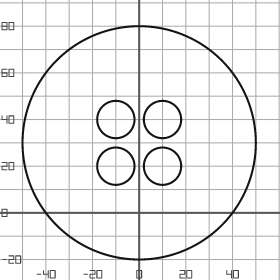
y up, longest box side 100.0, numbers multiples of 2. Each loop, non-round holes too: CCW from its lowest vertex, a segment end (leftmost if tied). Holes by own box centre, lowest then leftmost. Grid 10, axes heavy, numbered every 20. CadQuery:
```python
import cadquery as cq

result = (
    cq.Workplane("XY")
    .moveTo(0.0, 30.0)
    .circle(50.0)
    .moveTo(-10.0, 20.0)
    .circle(8.0)
    .moveTo(10.0, 20.0)
    .circle(8.0)
    .moveTo(-10.0, 40.0)
    .circle(8.0)
    .moveTo(10.0, 40.0)
    .circle(8.0)
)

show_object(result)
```